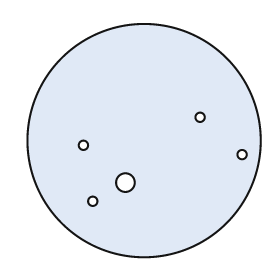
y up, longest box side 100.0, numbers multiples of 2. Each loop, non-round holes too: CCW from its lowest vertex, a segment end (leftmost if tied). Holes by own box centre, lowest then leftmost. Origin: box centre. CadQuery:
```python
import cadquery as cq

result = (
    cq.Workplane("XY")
    .moveTo(0.0, 0.0)
    .circle(50.0)
    .moveTo(-22.0, -26.0)
    .circle(2.0)
    .moveTo(-8.0, -18.0)
    .circle(4.0)
    .moveTo(42.0, -6.0)
    .circle(2.0)
    .moveTo(-26.0, -2.0)
    .circle(2.0)
    .moveTo(24.0, 10.0)
    .circle(2.0)
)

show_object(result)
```